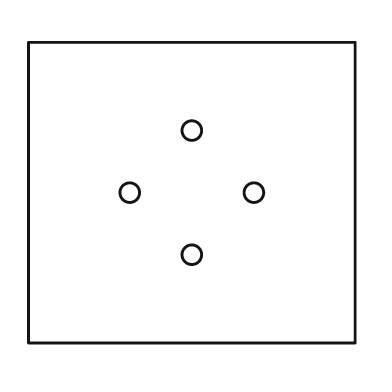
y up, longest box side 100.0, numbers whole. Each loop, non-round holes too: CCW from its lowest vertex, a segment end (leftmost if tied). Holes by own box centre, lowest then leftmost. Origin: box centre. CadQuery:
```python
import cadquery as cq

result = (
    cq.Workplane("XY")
    .moveTo(-50.0, -46.0)
    .lineTo(50.0, -46.0)
    .lineTo(50.0, 46.0)
    .lineTo(-50.0, 46.0)
    .close()
    .moveTo(0.0, -19.0)
    .circle(3.0)
    .moveTo(-19.0, 0.0)
    .circle(3.0)
    .moveTo(19.0, 0.0)
    .circle(3.0)
    .moveTo(0.0, 19.0)
    .circle(3.0)
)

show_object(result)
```